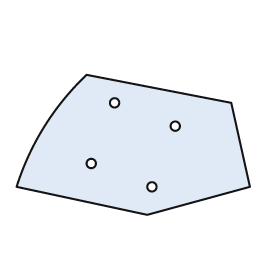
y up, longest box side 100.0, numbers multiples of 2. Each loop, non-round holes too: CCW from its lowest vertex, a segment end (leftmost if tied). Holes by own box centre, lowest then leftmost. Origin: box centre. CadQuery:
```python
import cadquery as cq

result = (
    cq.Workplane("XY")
    .moveTo(6.0, -30.0)
    .lineTo(50.0, -18.0)
    .lineTo(42.0, 18.0)
    .lineTo(-20.0, 30.0)
    .threePointArc((-38.0, 8.0), (-50.0, -18.0))
    .close()
    .moveTo(8.0, -18.0)
    .circle(2.0)
    .moveTo(-18.0, -8.0)
    .circle(2.0)
    .moveTo(18.0, 8.0)
    .circle(2.0)
    .moveTo(-8.0, 18.0)
    .circle(2.0)
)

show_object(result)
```